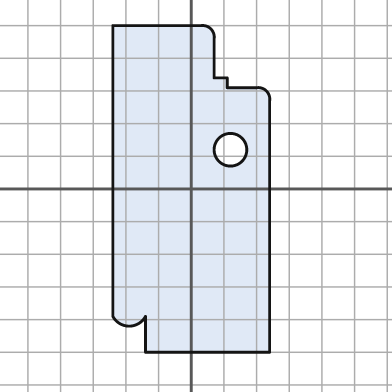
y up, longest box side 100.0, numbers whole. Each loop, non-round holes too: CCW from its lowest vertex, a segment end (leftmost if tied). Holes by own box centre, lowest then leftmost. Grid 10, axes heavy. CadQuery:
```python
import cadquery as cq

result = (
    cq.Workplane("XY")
    .moveTo(-14.0, -50.0)
    .lineTo(24.0, -50.0)
    .lineTo(24.0, 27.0)
    .threePointArc((23.0, 30.0), (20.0, 31.0))
    .lineTo(11.0, 31.0)
    .lineTo(11.0, 34.0)
    .lineTo(7.0, 34.0)
    .lineTo(7.0, 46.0)
    .threePointArc((6.0, 49.0), (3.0, 50.0))
    .lineTo(-24.0, 50.0)
    .lineTo(-24.0, -39.0)
    .threePointArc((-19.0, -42.0), (-14.0, -39.0))
    .close()
    .moveTo(12.0, 12.0)
    .circle(5.0)
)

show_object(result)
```